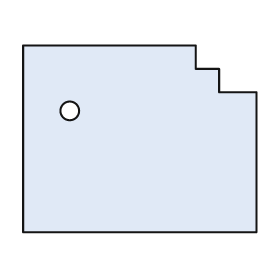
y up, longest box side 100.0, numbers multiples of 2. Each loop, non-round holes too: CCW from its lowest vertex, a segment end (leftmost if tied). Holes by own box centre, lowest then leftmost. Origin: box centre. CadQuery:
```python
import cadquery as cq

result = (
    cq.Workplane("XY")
    .moveTo(-50.0, -40.0)
    .lineTo(50.0, -40.0)
    .lineTo(50.0, 20.0)
    .lineTo(34.0, 20.0)
    .lineTo(34.0, 30.0)
    .lineTo(24.0, 30.0)
    .lineTo(24.0, 40.0)
    .lineTo(-50.0, 40.0)
    .close()
    .moveTo(-30.0, 12.0)
    .circle(4.0)
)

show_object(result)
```